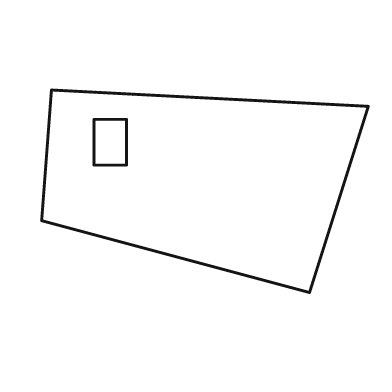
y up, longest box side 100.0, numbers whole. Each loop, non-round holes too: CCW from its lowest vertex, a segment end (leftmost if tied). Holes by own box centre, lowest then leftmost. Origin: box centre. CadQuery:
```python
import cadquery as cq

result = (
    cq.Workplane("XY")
    .moveTo(32.0, -31.0)
    .lineTo(50.0, 26.0)
    .lineTo(-47.0, 31.0)
    .lineTo(-50.0, -9.0)
    .close()
    .moveTo(-34.0, 8.0)
    .lineTo(-24.0, 8.0)
    .lineTo(-24.0, 22.0)
    .lineTo(-34.0, 22.0)
    .close()
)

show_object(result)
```